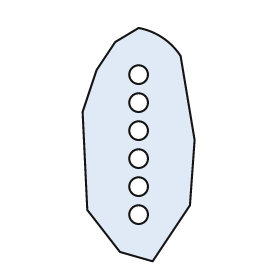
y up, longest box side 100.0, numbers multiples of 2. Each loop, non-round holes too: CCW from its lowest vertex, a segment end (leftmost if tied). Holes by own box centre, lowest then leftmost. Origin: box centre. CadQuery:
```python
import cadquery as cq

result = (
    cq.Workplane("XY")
    .moveTo(6.0, -50.0)
    .lineTo(22.0, -26.0)
    .lineTo(24.0, 2.0)
    .lineTo(18.0, 38.0)
    .threePointArc((10.0, 46.0), (0.0, 50.0))
    .lineTo(-10.0, 44.0)
    .lineTo(-18.0, 32.0)
    .lineTo(-24.0, 14.0)
    .lineTo(-22.0, -28.0)
    .lineTo(-8.0, -46.0)
    .close()
    .moveTo(0.0, -30.0)
    .circle(4.0)
    .moveTo(0.0, -18.0)
    .circle(4.0)
    .moveTo(0.0, -6.0)
    .circle(4.0)
    .moveTo(0.0, 6.0)
    .circle(4.0)
    .moveTo(0.0, 18.0)
    .circle(4.0)
    .moveTo(0.0, 30.0)
    .circle(4.0)
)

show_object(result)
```